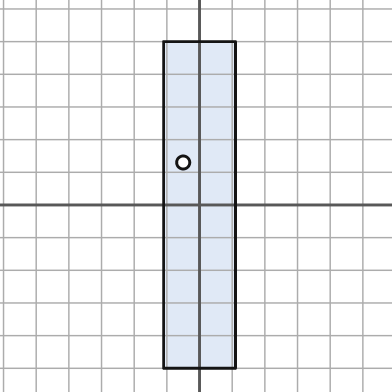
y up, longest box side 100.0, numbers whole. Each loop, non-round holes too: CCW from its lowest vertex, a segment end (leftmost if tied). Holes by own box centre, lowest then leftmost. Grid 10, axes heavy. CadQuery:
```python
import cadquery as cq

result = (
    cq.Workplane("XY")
    .moveTo(-11.0, -50.0)
    .lineTo(11.0, -50.0)
    .lineTo(11.0, 50.0)
    .lineTo(-11.0, 50.0)
    .close()
    .moveTo(-5.0, 13.0)
    .circle(2.0)
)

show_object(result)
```